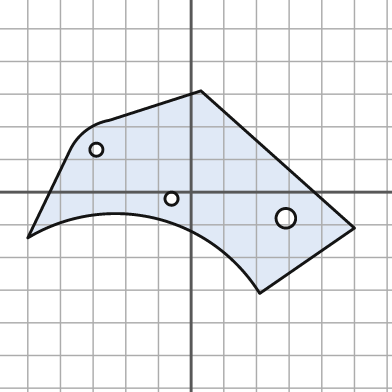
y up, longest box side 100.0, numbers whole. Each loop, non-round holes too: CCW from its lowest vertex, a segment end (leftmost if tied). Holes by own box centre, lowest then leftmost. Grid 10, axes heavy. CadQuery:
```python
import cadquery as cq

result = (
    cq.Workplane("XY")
    .moveTo(21.0, -31.0)
    .lineTo(50.0, -11.0)
    .lineTo(3.0, 31.0)
    .lineTo(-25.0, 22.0)
    .threePointArc((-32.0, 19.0), (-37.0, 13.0))
    .lineTo(-50.0, -14.0)
    .threePointArc((-11.0, -8.0), (21.0, -31.0))
    .close()
    .moveTo(29.0, -8.0)
    .circle(3.0)
    .moveTo(-6.0, -2.0)
    .circle(2.0)
    .moveTo(-29.0, 13.0)
    .circle(2.0)
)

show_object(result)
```